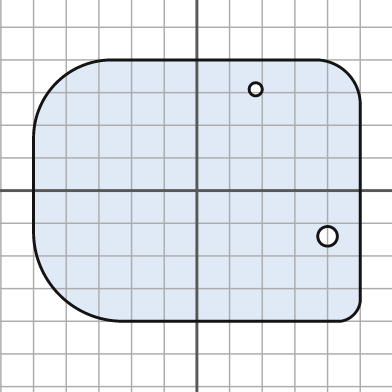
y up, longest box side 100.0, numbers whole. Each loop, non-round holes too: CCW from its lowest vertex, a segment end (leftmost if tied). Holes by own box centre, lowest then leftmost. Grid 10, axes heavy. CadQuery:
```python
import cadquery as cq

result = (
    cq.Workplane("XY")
    .moveTo(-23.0, -40.0)
    .lineTo(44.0, -40.0)
    .threePointArc((48.0, -38.0), (50.0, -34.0))
    .lineTo(50.0, 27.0)
    .threePointArc((46.0, 36.0), (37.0, 40.0))
    .lineTo(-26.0, 40.0)
    .threePointArc((-43.0, 33.0), (-50.0, 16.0))
    .lineTo(-50.0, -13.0)
    .threePointArc((-42.0, -32.0), (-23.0, -40.0))
    .close()
    .moveTo(40.0, -14.0)
    .circle(3.0)
    .moveTo(18.0, 31.0)
    .circle(2.0)
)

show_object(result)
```